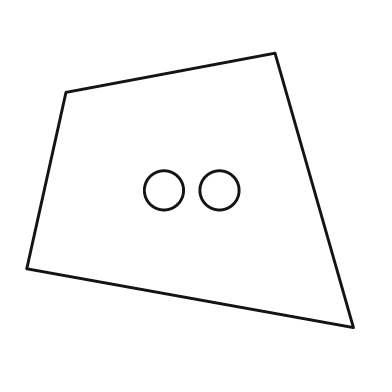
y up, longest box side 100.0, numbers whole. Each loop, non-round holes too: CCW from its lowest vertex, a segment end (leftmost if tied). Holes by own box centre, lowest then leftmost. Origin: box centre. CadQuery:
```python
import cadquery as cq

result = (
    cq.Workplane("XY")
    .moveTo(50.0, -42.0)
    .lineTo(26.0, 42.0)
    .lineTo(-38.0, 30.0)
    .lineTo(-50.0, -24.0)
    .close()
    .moveTo(-8.0, 0.0)
    .circle(6.0)
    .moveTo(9.0, 0.0)
    .circle(6.0)
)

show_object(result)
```